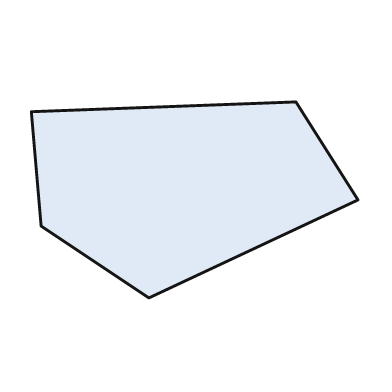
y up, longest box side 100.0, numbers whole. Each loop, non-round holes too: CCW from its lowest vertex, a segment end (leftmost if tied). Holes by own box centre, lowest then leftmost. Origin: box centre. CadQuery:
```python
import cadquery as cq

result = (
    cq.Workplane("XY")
    .moveTo(-14.0, -30.0)
    .lineTo(50.0, 0.0)
    .lineTo(31.0, 30.0)
    .lineTo(-50.0, 27.0)
    .lineTo(-47.0, -8.0)
    .close()
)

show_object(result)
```